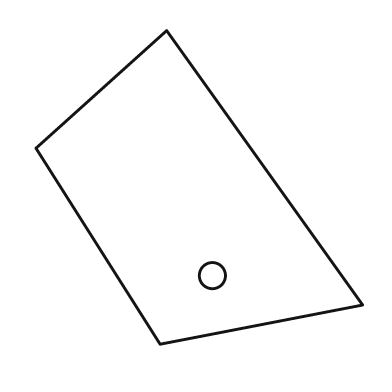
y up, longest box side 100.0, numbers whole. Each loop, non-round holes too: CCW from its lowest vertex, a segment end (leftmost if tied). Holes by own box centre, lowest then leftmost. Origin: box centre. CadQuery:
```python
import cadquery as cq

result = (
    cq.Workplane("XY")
    .moveTo(-12.0, -48.0)
    .lineTo(50.0, -36.0)
    .lineTo(-10.0, 48.0)
    .lineTo(-50.0, 12.0)
    .close()
    .moveTo(4.0, -27.0)
    .circle(4.0)
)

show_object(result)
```